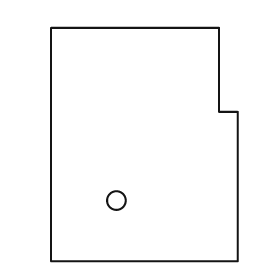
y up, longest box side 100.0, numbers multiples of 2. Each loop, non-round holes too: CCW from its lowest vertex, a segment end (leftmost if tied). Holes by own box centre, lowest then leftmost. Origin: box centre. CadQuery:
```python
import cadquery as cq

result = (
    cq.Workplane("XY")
    .moveTo(-40.0, -50.0)
    .lineTo(40.0, -50.0)
    .lineTo(40.0, 14.0)
    .lineTo(32.0, 14.0)
    .lineTo(32.0, 50.0)
    .lineTo(-40.0, 50.0)
    .close()
    .moveTo(-12.0, -24.0)
    .circle(4.0)
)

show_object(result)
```